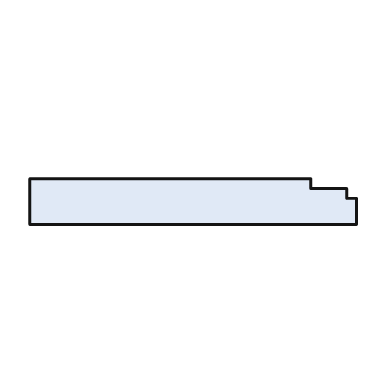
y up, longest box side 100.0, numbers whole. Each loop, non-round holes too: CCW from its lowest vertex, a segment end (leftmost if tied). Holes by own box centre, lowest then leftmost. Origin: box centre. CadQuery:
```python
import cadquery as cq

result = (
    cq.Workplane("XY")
    .moveTo(-50.0, -7.0)
    .lineTo(50.0, -7.0)
    .lineTo(50.0, 1.0)
    .lineTo(47.0, 1.0)
    .lineTo(47.0, 4.0)
    .lineTo(36.0, 4.0)
    .lineTo(36.0, 7.0)
    .lineTo(-50.0, 7.0)
    .close()
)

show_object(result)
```